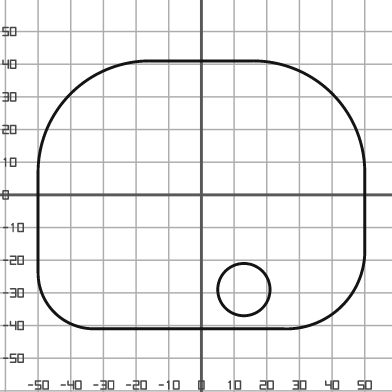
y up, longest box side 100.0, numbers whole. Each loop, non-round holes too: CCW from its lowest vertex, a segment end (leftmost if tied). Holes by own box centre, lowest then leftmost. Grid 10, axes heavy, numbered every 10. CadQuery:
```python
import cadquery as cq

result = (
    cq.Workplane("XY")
    .moveTo(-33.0, -41.0)
    .lineTo(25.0, -41.0)
    .threePointArc((43.0, -34.0), (50.0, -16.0))
    .lineTo(50.0, 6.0)
    .threePointArc((40.0, 31.0), (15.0, 41.0))
    .lineTo(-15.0, 41.0)
    .threePointArc((-40.0, 31.0), (-50.0, 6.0))
    .lineTo(-50.0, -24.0)
    .threePointArc((-45.0, -36.0), (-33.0, -41.0))
    .close()
    .moveTo(13.0, -29.0)
    .circle(8.0)
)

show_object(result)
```